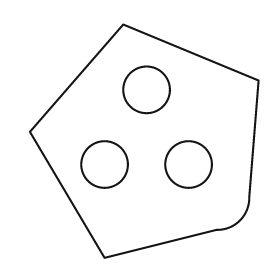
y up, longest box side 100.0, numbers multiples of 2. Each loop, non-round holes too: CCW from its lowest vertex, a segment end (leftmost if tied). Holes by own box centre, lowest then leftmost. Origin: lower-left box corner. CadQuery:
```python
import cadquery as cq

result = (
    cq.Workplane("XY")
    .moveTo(32.0, 0.0)
    .lineTo(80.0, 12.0)
    .threePointArc((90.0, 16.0), (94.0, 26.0))
    .lineTo(98.0, 76.0)
    .lineTo(40.0, 100.0)
    .lineTo(0.0, 54.0)
    .close()
    .moveTo(32.0, 40.0)
    .circle(10.0)
    .moveTo(68.0, 40.0)
    .circle(10.0)
    .moveTo(50.0, 72.0)
    .circle(10.0)
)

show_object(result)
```